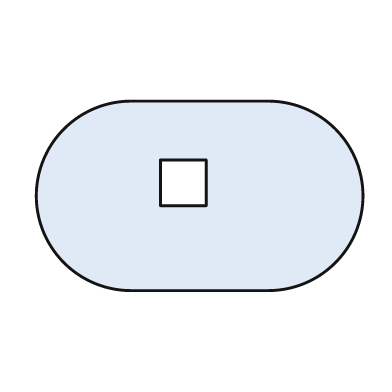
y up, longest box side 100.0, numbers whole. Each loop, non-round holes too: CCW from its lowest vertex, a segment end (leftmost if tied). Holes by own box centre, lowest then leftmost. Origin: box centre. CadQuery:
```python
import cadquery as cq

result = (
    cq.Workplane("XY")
    .moveTo(-21.0, -29.0)
    .lineTo(21.0, -29.0)
    .threePointArc((50.0, 0.0), (21.0, 29.0))
    .lineTo(-21.0, 29.0)
    .threePointArc((-50.0, 0.0), (-21.0, -29.0))
    .close()
    .moveTo(-12.0, -3.0)
    .lineTo(2.0, -3.0)
    .lineTo(2.0, 11.0)
    .lineTo(-12.0, 11.0)
    .close()
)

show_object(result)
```